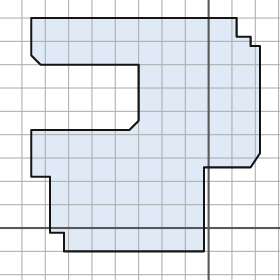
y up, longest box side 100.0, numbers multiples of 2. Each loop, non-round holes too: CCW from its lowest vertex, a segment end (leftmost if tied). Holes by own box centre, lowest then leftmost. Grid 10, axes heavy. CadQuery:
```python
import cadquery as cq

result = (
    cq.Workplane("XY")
    .moveTo(-62.0, -10.0)
    .lineTo(-2.0, -10.0)
    .lineTo(-2.0, 26.0)
    .lineTo(18.0, 26.0)
    .lineTo(22.0, 32.0)
    .lineTo(22.0, 78.0)
    .lineTo(18.0, 78.0)
    .lineTo(18.0, 82.0)
    .lineTo(12.0, 82.0)
    .lineTo(12.0, 90.0)
    .lineTo(-76.0, 90.0)
    .lineTo(-76.0, 74.0)
    .lineTo(-72.0, 70.0)
    .lineTo(-30.0, 70.0)
    .lineTo(-30.0, 46.0)
    .lineTo(-34.0, 42.0)
    .lineTo(-76.0, 42.0)
    .lineTo(-76.0, 22.0)
    .lineTo(-68.0, 22.0)
    .lineTo(-68.0, -2.0)
    .lineTo(-62.0, -2.0)
    .close()
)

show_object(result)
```